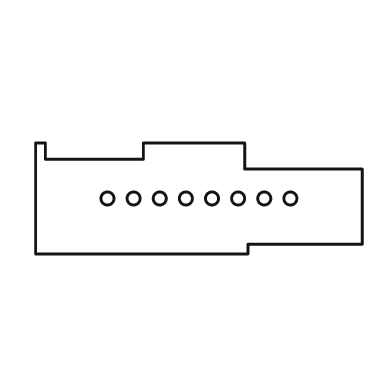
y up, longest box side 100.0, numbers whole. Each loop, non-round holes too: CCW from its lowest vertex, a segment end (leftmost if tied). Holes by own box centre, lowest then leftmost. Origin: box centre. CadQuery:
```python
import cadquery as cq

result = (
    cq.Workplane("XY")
    .moveTo(-50.0, -17.0)
    .lineTo(15.0, -17.0)
    .lineTo(15.0, -14.0)
    .lineTo(50.0, -14.0)
    .lineTo(50.0, 9.0)
    .lineTo(14.0, 9.0)
    .lineTo(14.0, 17.0)
    .lineTo(-17.0, 17.0)
    .lineTo(-17.0, 12.0)
    .lineTo(-47.0, 12.0)
    .lineTo(-47.0, 17.0)
    .lineTo(-50.0, 17.0)
    .close()
    .moveTo(-28.0, 0.0)
    .circle(2.0)
    .moveTo(-20.0, 0.0)
    .circle(2.0)
    .moveTo(-12.0, 0.0)
    .circle(2.0)
    .moveTo(-4.0, 0.0)
    .circle(2.0)
    .moveTo(4.0, 0.0)
    .circle(2.0)
    .moveTo(12.0, 0.0)
    .circle(2.0)
    .moveTo(20.0, 0.0)
    .circle(2.0)
    .moveTo(28.0, 0.0)
    .circle(2.0)
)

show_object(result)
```